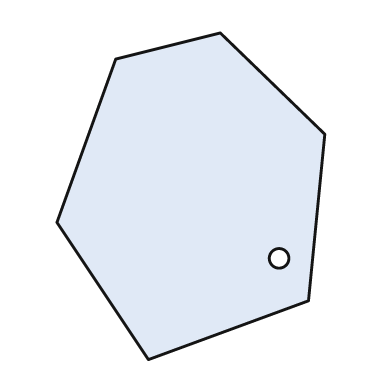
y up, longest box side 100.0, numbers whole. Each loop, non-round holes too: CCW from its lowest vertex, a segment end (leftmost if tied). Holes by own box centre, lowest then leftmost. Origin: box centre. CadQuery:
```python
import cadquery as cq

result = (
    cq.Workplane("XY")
    .moveTo(-13.0, -50.0)
    .lineTo(36.0, -32.0)
    .lineTo(41.0, 19.0)
    .lineTo(9.0, 50.0)
    .lineTo(-23.0, 42.0)
    .lineTo(-41.0, -8.0)
    .close()
    .moveTo(27.0, -19.0)
    .circle(3.0)
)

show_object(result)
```